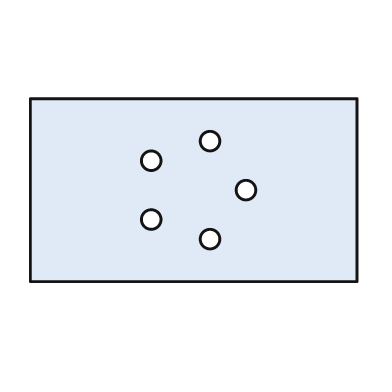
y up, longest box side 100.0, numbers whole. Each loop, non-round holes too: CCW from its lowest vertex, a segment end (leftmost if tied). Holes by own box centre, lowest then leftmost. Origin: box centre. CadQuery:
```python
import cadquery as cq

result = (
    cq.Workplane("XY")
    .moveTo(-50.0, -28.0)
    .lineTo(50.0, -28.0)
    .lineTo(50.0, 28.0)
    .lineTo(-50.0, 28.0)
    .close()
    .moveTo(5.0, -15.0)
    .circle(3.0)
    .moveTo(-13.0, -9.0)
    .circle(3.0)
    .moveTo(16.0, 0.0)
    .circle(3.0)
    .moveTo(-13.0, 9.0)
    .circle(3.0)
    .moveTo(5.0, 15.0)
    .circle(3.0)
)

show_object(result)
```